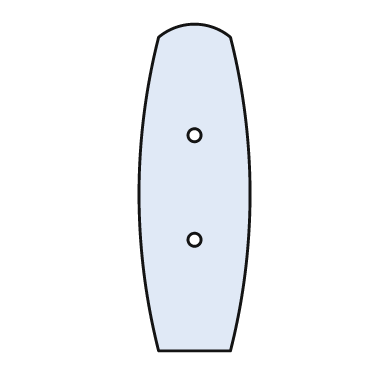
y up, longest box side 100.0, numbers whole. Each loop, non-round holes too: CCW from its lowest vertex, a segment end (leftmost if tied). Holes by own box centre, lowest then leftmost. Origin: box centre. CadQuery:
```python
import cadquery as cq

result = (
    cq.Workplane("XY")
    .moveTo(-11.0, -50.0)
    .lineTo(11.0, -50.0)
    .threePointArc((17.0, -2.0), (11.0, 46.0))
    .threePointArc((0.0, 50.0), (-11.0, 46.0))
    .threePointArc((-17.0, -2.0), (-11.0, -50.0))
    .close()
    .moveTo(0.0, -16.0)
    .circle(2.0)
    .moveTo(0.0, 16.0)
    .circle(2.0)
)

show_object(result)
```